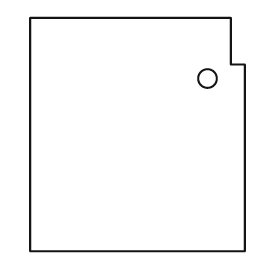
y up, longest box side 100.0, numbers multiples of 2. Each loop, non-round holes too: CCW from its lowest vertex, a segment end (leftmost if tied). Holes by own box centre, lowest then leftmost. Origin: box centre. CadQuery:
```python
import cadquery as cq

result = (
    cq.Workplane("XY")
    .moveTo(-46.0, -50.0)
    .lineTo(46.0, -50.0)
    .lineTo(46.0, 30.0)
    .lineTo(40.0, 30.0)
    .lineTo(40.0, 50.0)
    .lineTo(-46.0, 50.0)
    .close()
    .moveTo(30.0, 24.0)
    .circle(4.0)
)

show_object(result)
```